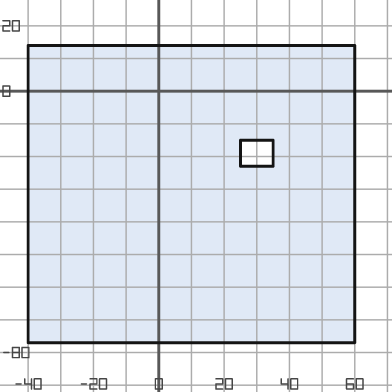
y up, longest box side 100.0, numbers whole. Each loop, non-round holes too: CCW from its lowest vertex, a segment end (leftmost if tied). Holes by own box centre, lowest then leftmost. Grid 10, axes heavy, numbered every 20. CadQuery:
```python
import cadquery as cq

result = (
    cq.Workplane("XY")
    .moveTo(-40.0, -77.0)
    .lineTo(60.0, -77.0)
    .lineTo(60.0, 14.0)
    .lineTo(-40.0, 14.0)
    .close()
    .moveTo(25.0, -23.0)
    .lineTo(35.0, -23.0)
    .lineTo(35.0, -15.0)
    .lineTo(25.0, -15.0)
    .close()
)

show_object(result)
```